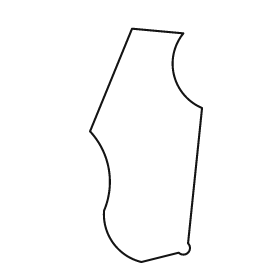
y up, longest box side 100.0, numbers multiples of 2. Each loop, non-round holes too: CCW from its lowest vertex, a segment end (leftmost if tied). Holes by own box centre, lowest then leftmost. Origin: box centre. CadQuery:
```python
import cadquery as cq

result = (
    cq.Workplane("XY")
    .moveTo(-2.0, -50.0)
    .lineTo(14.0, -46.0)
    .threePointArc((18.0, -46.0), (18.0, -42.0))
    .lineTo(24.0, 16.0)
    .threePointArc((12.0, 30.0), (16.0, 48.0))
    .lineTo(-6.0, 50.0)
    .lineTo(-24.0, 6.0)
    .threePointArc((-16.0, -10.0), (-18.0, -28.0))
    .threePointArc((-14.0, -42.0), (-2.0, -50.0))
    .close()
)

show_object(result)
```